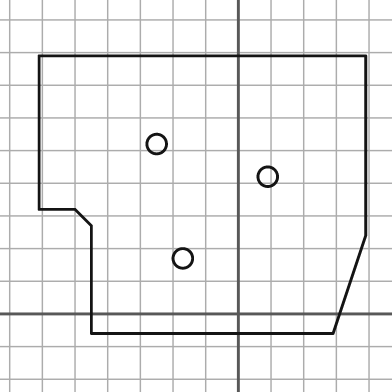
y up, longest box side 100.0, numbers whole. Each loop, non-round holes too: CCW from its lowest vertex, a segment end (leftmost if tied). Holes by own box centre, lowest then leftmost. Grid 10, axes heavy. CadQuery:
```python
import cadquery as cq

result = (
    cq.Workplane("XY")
    .moveTo(-45.0, -6.0)
    .lineTo(29.0, -6.0)
    .lineTo(39.0, 24.0)
    .lineTo(39.0, 79.0)
    .lineTo(-61.0, 79.0)
    .lineTo(-61.0, 32.0)
    .lineTo(-50.0, 32.0)
    .lineTo(-45.0, 27.0)
    .close()
    .moveTo(-17.0, 17.0)
    .circle(3.0)
    .moveTo(9.0, 42.0)
    .circle(3.0)
    .moveTo(-25.0, 52.0)
    .circle(3.0)
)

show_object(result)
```